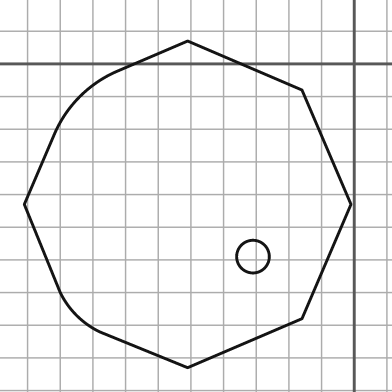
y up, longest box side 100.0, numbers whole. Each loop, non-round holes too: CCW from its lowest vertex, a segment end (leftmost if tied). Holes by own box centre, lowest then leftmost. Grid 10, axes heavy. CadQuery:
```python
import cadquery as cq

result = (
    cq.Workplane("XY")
    .moveTo(-51.0, -93.0)
    .lineTo(-16.0, -78.0)
    .lineTo(-1.0, -43.0)
    .lineTo(-16.0, -8.0)
    .lineTo(-51.0, 7.0)
    .lineTo(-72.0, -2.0)
    .threePointArc((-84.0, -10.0), (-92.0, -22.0))
    .lineTo(-101.0, -43.0)
    .lineTo(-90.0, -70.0)
    .threePointArc((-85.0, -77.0), (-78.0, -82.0))
    .close()
    .moveTo(-31.0, -59.0)
    .circle(5.0)
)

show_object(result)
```